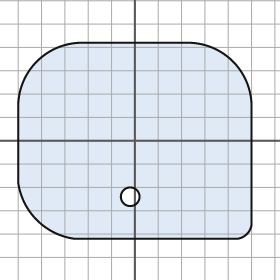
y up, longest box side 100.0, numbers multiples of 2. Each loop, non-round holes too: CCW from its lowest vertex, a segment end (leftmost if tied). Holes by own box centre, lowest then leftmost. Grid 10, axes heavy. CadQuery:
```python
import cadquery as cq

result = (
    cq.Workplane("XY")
    .moveTo(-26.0, -42.0)
    .lineTo(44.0, -42.0)
    .threePointArc((48.0, -40.0), (50.0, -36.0))
    .lineTo(50.0, 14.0)
    .threePointArc((42.0, 34.0), (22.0, 42.0))
    .lineTo(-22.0, 42.0)
    .threePointArc((-42.0, 34.0), (-50.0, 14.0))
    .lineTo(-50.0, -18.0)
    .threePointArc((-42.0, -34.0), (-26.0, -42.0))
    .close()
    .moveTo(-2.0, -24.0)
    .circle(4.0)
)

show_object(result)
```